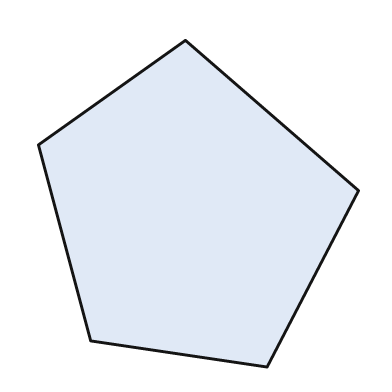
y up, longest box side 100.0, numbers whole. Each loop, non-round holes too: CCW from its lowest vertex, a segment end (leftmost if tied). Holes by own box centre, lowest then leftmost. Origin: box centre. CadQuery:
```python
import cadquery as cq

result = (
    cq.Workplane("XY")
    .moveTo(21.0, -50.0)
    .lineTo(49.0, 4.0)
    .lineTo(-4.0, 50.0)
    .lineTo(-49.0, 18.0)
    .lineTo(-33.0, -42.0)
    .close()
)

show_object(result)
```